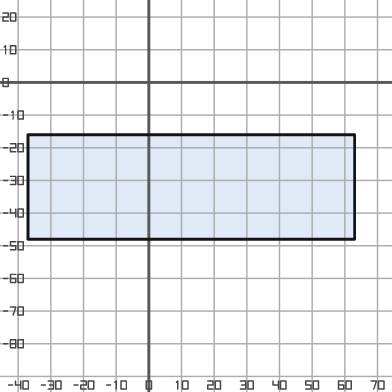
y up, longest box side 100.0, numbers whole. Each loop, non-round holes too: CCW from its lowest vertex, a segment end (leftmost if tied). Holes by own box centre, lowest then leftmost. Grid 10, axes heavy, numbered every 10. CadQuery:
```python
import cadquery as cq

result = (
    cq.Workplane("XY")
    .moveTo(-37.0, -48.0)
    .lineTo(63.0, -48.0)
    .lineTo(63.0, -16.0)
    .lineTo(-37.0, -16.0)
    .close()
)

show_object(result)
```